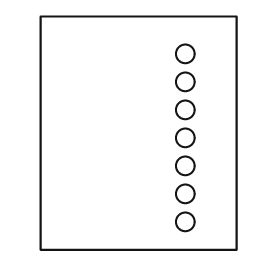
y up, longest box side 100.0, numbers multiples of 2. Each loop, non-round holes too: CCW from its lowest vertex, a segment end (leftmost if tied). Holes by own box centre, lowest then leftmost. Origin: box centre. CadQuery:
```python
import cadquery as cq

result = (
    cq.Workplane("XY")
    .moveTo(-42.0, -50.0)
    .lineTo(42.0, -50.0)
    .lineTo(42.0, 50.0)
    .lineTo(-42.0, 50.0)
    .close()
    .moveTo(20.0, -38.0)
    .circle(4.0)
    .moveTo(20.0, -26.0)
    .circle(4.0)
    .moveTo(20.0, -14.0)
    .circle(4.0)
    .moveTo(20.0, -2.0)
    .circle(4.0)
    .moveTo(20.0, 10.0)
    .circle(4.0)
    .moveTo(20.0, 22.0)
    .circle(4.0)
    .moveTo(20.0, 34.0)
    .circle(4.0)
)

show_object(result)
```